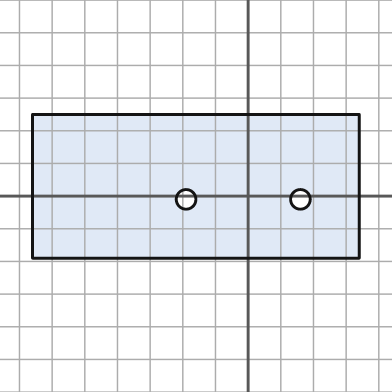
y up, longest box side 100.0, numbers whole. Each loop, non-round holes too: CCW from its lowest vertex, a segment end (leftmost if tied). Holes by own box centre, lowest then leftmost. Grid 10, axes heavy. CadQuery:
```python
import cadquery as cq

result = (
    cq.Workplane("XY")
    .moveTo(-66.0, -19.0)
    .lineTo(34.0, -19.0)
    .lineTo(34.0, 25.0)
    .lineTo(-66.0, 25.0)
    .close()
    .moveTo(-19.0, -1.0)
    .circle(3.0)
    .moveTo(16.0, -1.0)
    .circle(3.0)
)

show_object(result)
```